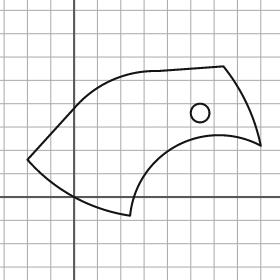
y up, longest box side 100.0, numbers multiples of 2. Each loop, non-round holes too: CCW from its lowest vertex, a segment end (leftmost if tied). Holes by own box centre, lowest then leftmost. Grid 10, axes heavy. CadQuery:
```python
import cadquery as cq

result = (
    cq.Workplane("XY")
    .moveTo(24.0, -8.0)
    .threePointArc((44.0, 22.0), (80.0, 22.0))
    .threePointArc((74.0, 40.0), (64.0, 56.0))
    .lineTo(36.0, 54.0)
    .threePointArc((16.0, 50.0), (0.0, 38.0))
    .lineTo(-20.0, 16.0)
    .threePointArc((0.0, 0.0), (24.0, -8.0))
    .close()
    .moveTo(54.0, 36.0)
    .circle(4.0)
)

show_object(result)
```